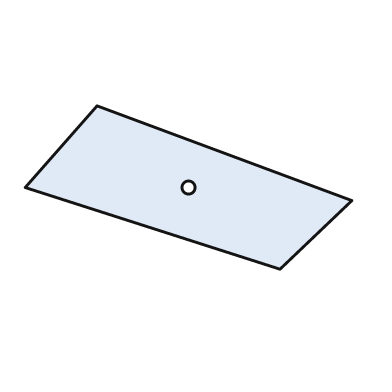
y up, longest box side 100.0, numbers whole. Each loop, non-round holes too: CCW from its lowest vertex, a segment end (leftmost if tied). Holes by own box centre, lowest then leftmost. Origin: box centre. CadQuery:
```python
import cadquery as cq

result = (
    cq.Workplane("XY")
    .moveTo(28.0, -25.0)
    .lineTo(50.0, -4.0)
    .lineTo(-28.0, 25.0)
    .lineTo(-50.0, 0.0)
    .close()
    .moveTo(0.0, 0.0)
    .circle(2.0)
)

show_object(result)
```